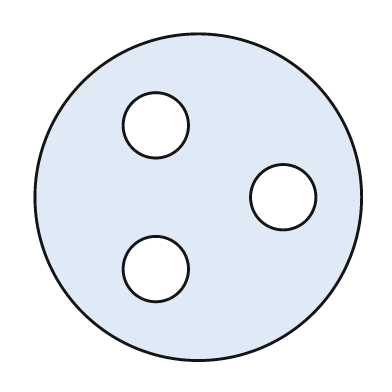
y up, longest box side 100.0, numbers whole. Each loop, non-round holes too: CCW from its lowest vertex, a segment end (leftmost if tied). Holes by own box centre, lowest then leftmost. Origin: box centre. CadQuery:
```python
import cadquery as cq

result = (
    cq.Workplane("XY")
    .moveTo(0.0, 0.0)
    .circle(50.0)
    .moveTo(-13.0, -22.0)
    .circle(10.0)
    .moveTo(26.0, 0.0)
    .circle(10.0)
    .moveTo(-13.0, 22.0)
    .circle(10.0)
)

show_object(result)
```